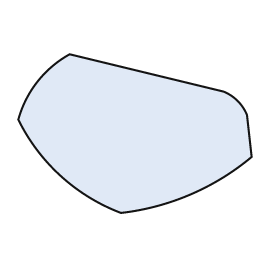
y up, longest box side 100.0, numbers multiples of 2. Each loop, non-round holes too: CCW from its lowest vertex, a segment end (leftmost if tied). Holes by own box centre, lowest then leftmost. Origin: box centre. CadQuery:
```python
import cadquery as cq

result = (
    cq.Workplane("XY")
    .moveTo(-6.0, -34.0)
    .threePointArc((24.0, -26.0), (50.0, -10.0))
    .lineTo(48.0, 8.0)
    .threePointArc((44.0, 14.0), (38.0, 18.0))
    .lineTo(-28.0, 34.0)
    .threePointArc((-42.0, 22.0), (-50.0, 6.0))
    .threePointArc((-32.0, -18.0), (-6.0, -34.0))
    .close()
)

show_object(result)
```